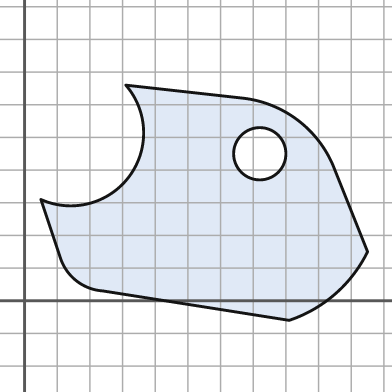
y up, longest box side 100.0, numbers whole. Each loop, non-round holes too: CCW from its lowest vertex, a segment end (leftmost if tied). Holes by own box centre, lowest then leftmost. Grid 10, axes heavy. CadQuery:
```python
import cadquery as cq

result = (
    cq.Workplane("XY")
    .moveTo(81.0, -6.0)
    .threePointArc((95.0, 2.0), (105.0, 15.0))
    .lineTo(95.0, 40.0)
    .threePointArc((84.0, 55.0), (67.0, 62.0))
    .lineTo(31.0, 66.0)
    .threePointArc((32.0, 38.0), (5.0, 31.0))
    .lineTo(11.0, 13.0)
    .threePointArc((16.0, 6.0), (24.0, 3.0))
    .close()
    .moveTo(72.0, 45.0)
    .circle(8.0)
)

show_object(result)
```